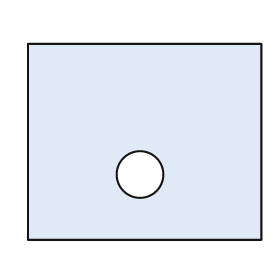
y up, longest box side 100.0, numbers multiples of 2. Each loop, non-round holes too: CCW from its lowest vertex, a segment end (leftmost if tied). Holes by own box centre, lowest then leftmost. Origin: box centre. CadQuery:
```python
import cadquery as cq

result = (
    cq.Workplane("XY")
    .moveTo(-50.0, -42.0)
    .lineTo(50.0, -42.0)
    .lineTo(50.0, 42.0)
    .lineTo(-50.0, 42.0)
    .close()
    .moveTo(-2.0, -14.0)
    .circle(10.0)
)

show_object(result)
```